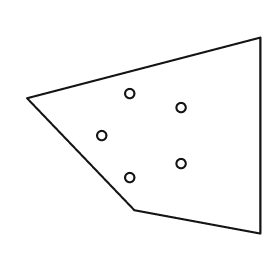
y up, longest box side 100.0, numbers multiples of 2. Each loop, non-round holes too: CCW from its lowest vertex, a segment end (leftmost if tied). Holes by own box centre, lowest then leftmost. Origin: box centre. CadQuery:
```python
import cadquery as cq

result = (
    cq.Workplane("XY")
    .moveTo(50.0, -42.0)
    .lineTo(50.0, 42.0)
    .lineTo(-50.0, 16.0)
    .lineTo(-4.0, -32.0)
    .close()
    .moveTo(-6.0, -18.0)
    .circle(2.0)
    .moveTo(16.0, -12.0)
    .circle(2.0)
    .moveTo(-18.0, 0.0)
    .circle(2.0)
    .moveTo(16.0, 12.0)
    .circle(2.0)
    .moveTo(-6.0, 18.0)
    .circle(2.0)
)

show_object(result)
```